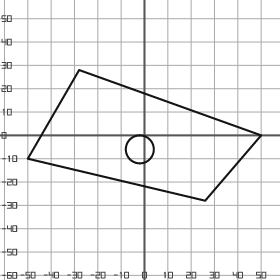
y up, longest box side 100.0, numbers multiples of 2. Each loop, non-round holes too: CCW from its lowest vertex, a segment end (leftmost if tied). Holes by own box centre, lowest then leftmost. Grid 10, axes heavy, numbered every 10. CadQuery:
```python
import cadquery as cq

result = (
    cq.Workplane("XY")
    .moveTo(26.0, -28.0)
    .lineTo(50.0, 0.0)
    .lineTo(-28.0, 28.0)
    .lineTo(-50.0, -10.0)
    .close()
    .moveTo(-2.0, -6.0)
    .circle(6.0)
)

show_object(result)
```